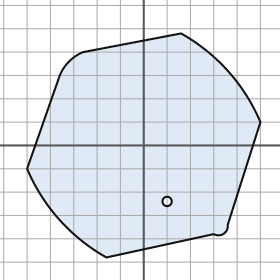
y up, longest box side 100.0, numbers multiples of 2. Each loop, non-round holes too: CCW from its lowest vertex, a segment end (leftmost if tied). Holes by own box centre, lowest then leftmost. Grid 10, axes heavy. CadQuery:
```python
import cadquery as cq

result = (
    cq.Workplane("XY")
    .moveTo(-16.0, -48.0)
    .lineTo(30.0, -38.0)
    .threePointArc((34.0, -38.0), (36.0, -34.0))
    .lineTo(50.0, 10.0)
    .threePointArc((36.0, 32.0), (16.0, 48.0))
    .lineTo(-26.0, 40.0)
    .threePointArc((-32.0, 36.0), (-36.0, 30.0))
    .lineTo(-50.0, -10.0)
    .threePointArc((-36.0, -32.0), (-16.0, -48.0))
    .close()
    .moveTo(10.0, -24.0)
    .circle(2.0)
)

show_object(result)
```